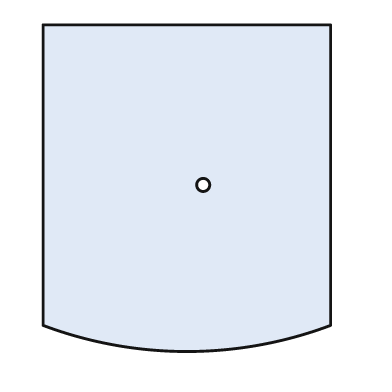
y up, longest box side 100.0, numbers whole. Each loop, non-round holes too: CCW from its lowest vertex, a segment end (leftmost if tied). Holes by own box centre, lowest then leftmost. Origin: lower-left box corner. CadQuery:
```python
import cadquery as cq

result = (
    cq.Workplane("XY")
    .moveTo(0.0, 8.0)
    .threePointArc((44.0, 0.0), (88.0, 8.0))
    .lineTo(88.0, 100.0)
    .lineTo(0.0, 100.0)
    .close()
    .moveTo(49.0, 51.0)
    .circle(2.0)
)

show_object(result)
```